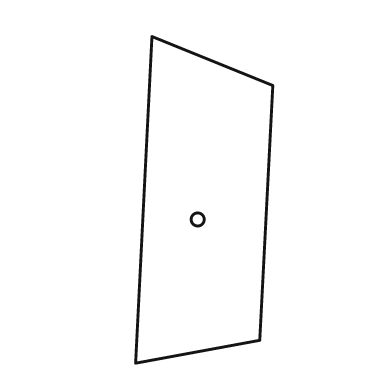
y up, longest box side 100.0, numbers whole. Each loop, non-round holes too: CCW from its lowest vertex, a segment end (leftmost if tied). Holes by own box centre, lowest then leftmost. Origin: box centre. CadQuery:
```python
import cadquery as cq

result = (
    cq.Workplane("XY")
    .moveTo(-21.0, -50.0)
    .lineTo(17.0, -43.0)
    .lineTo(21.0, 35.0)
    .lineTo(-16.0, 50.0)
    .close()
    .moveTo(-2.0, -6.0)
    .circle(2.0)
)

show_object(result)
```